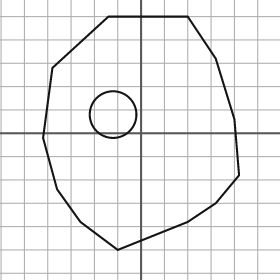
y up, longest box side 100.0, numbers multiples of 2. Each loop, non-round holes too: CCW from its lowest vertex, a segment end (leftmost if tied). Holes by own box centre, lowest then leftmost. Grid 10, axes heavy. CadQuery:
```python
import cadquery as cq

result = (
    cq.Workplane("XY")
    .moveTo(-10.0, -50.0)
    .lineTo(20.0, -38.0)
    .lineTo(32.0, -30.0)
    .lineTo(42.0, -18.0)
    .lineTo(40.0, 6.0)
    .lineTo(32.0, 32.0)
    .lineTo(20.0, 50.0)
    .lineTo(-14.0, 50.0)
    .lineTo(-38.0, 28.0)
    .lineTo(-42.0, -2.0)
    .lineTo(-36.0, -24.0)
    .lineTo(-26.0, -38.0)
    .close()
    .moveTo(-12.0, 8.0)
    .circle(10.0)
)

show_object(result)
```